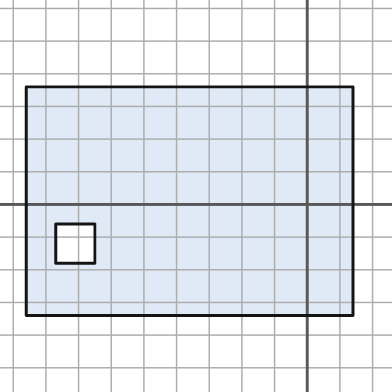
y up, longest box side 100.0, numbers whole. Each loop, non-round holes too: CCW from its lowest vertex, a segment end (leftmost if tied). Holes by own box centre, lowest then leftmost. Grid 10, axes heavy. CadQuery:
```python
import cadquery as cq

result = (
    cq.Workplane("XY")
    .moveTo(-86.0, -34.0)
    .lineTo(14.0, -34.0)
    .lineTo(14.0, 36.0)
    .lineTo(-86.0, 36.0)
    .close()
    .moveTo(-77.0, -18.0)
    .lineTo(-65.0, -18.0)
    .lineTo(-65.0, -6.0)
    .lineTo(-77.0, -6.0)
    .close()
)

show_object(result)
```